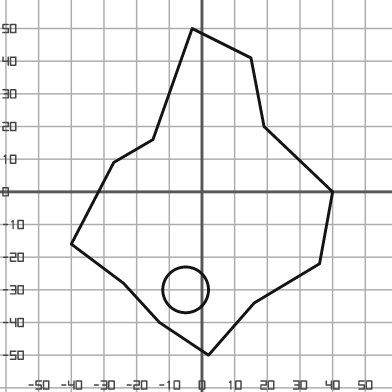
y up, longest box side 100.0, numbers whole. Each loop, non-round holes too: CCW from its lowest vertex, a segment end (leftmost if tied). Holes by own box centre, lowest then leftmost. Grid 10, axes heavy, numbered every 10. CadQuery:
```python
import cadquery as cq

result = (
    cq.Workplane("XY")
    .moveTo(2.0, -50.0)
    .lineTo(16.0, -34.0)
    .lineTo(36.0, -22.0)
    .lineTo(40.0, 0.0)
    .lineTo(19.0, 20.0)
    .lineTo(15.0, 41.0)
    .lineTo(-3.0, 50.0)
    .lineTo(-15.0, 16.0)
    .lineTo(-27.0, 9.0)
    .lineTo(-40.0, -16.0)
    .lineTo(-24.0, -28.0)
    .lineTo(-13.0, -40.0)
    .close()
    .moveTo(-5.0, -30.0)
    .circle(7.0)
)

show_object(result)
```